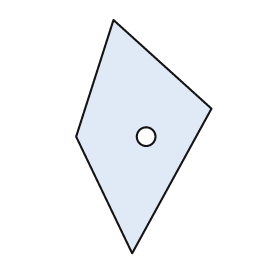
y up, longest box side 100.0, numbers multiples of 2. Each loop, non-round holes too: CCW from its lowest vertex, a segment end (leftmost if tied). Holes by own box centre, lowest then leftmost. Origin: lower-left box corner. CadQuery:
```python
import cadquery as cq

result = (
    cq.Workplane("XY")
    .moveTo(24.0, 0.0)
    .lineTo(58.0, 62.0)
    .lineTo(16.0, 100.0)
    .lineTo(0.0, 50.0)
    .close()
    .moveTo(30.0, 50.0)
    .circle(4.0)
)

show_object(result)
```